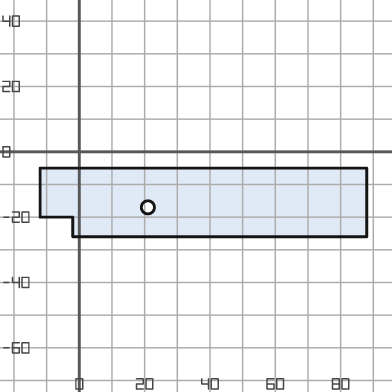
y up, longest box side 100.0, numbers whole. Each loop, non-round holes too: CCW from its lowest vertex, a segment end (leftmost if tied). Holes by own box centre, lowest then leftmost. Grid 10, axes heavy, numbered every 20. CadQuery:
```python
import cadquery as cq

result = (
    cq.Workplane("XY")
    .moveTo(-2.0, -26.0)
    .lineTo(88.0, -26.0)
    .lineTo(88.0, -5.0)
    .lineTo(-12.0, -5.0)
    .lineTo(-12.0, -20.0)
    .lineTo(-2.0, -20.0)
    .close()
    .moveTo(21.0, -17.0)
    .circle(2.0)
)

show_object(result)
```